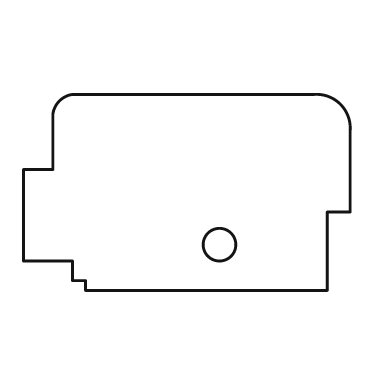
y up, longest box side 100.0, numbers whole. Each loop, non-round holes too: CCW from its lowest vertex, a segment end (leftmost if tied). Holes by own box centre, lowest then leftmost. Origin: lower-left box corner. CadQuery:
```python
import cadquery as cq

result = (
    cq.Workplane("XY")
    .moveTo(19.0, 0.0)
    .lineTo(93.0, 0.0)
    .lineTo(93.0, 24.0)
    .lineTo(100.0, 24.0)
    .lineTo(100.0, 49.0)
    .threePointArc((97.0, 57.0), (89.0, 60.0))
    .lineTo(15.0, 60.0)
    .threePointArc((11.0, 58.0), (9.0, 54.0))
    .lineTo(9.0, 37.0)
    .lineTo(0.0, 37.0)
    .lineTo(0.0, 9.0)
    .lineTo(15.0, 9.0)
    .lineTo(15.0, 3.0)
    .lineTo(19.0, 3.0)
    .close()
    .moveTo(60.0, 14.0)
    .circle(5.0)
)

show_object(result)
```